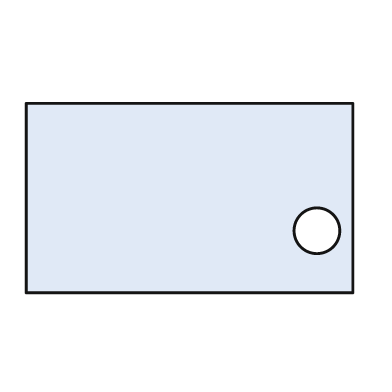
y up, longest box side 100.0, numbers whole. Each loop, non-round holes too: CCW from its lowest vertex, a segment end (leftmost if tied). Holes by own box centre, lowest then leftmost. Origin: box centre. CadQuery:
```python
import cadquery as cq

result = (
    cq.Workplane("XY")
    .moveTo(-50.0, -29.0)
    .lineTo(50.0, -29.0)
    .lineTo(50.0, 29.0)
    .lineTo(-50.0, 29.0)
    .close()
    .moveTo(39.0, -10.0)
    .circle(7.0)
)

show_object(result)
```